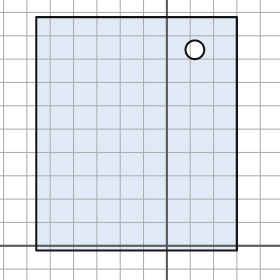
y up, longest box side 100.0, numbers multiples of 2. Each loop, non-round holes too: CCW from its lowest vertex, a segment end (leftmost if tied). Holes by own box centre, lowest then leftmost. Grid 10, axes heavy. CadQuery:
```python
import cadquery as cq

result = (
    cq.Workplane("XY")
    .moveTo(-56.0, -2.0)
    .lineTo(30.0, -2.0)
    .lineTo(30.0, 98.0)
    .lineTo(-56.0, 98.0)
    .close()
    .moveTo(12.0, 84.0)
    .circle(4.0)
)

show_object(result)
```